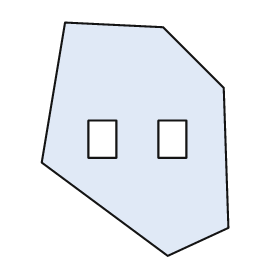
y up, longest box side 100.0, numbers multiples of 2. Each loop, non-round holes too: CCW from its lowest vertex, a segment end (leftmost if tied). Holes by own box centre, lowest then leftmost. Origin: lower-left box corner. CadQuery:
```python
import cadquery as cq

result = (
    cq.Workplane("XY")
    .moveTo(54.0, 0.0)
    .lineTo(80.0, 12.0)
    .lineTo(78.0, 72.0)
    .lineTo(52.0, 98.0)
    .lineTo(10.0, 100.0)
    .lineTo(0.0, 40.0)
    .close()
    .moveTo(20.0, 42.0)
    .lineTo(32.0, 42.0)
    .lineTo(32.0, 58.0)
    .lineTo(20.0, 58.0)
    .close()
    .moveTo(50.0, 42.0)
    .lineTo(62.0, 42.0)
    .lineTo(62.0, 58.0)
    .lineTo(50.0, 58.0)
    .close()
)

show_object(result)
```